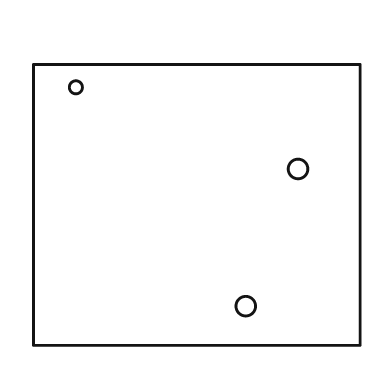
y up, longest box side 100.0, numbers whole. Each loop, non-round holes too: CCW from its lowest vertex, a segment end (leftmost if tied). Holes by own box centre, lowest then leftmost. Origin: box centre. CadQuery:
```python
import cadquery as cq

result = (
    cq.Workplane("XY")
    .moveTo(-50.0, -43.0)
    .lineTo(50.0, -43.0)
    .lineTo(50.0, 43.0)
    .lineTo(-50.0, 43.0)
    .close()
    .moveTo(15.0, -31.0)
    .circle(3.0)
    .moveTo(31.0, 11.0)
    .circle(3.0)
    .moveTo(-37.0, 36.0)
    .circle(2.0)
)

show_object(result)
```